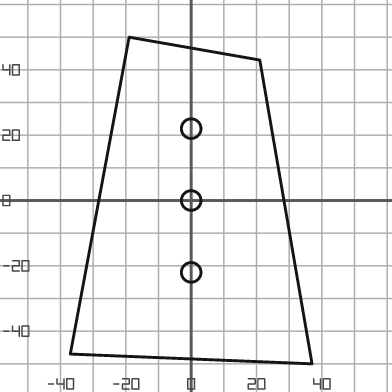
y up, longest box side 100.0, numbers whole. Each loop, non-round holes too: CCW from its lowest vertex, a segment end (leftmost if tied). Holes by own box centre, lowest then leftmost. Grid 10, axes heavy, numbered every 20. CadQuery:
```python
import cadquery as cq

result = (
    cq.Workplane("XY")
    .moveTo(37.0, -50.0)
    .lineTo(21.0, 43.0)
    .lineTo(-19.0, 50.0)
    .lineTo(-37.0, -47.0)
    .close()
    .moveTo(0.0, -22.0)
    .circle(3.0)
    .moveTo(0.0, 0.0)
    .circle(3.0)
    .moveTo(0.0, 22.0)
    .circle(3.0)
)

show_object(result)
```